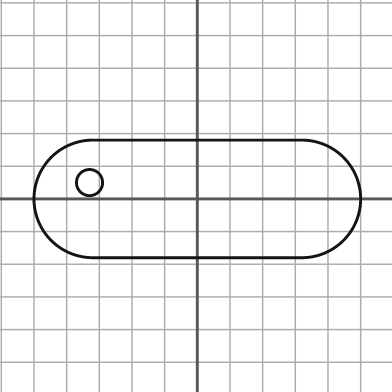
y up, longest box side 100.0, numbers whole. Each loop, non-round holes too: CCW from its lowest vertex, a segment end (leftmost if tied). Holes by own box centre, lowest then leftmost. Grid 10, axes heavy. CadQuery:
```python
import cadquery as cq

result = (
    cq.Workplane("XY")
    .moveTo(-32.0, -18.0)
    .lineTo(32.0, -18.0)
    .threePointArc((50.0, 0.0), (32.0, 18.0))
    .lineTo(-32.0, 18.0)
    .threePointArc((-50.0, 0.0), (-32.0, -18.0))
    .close()
    .moveTo(-33.0, 5.0)
    .circle(4.0)
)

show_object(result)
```